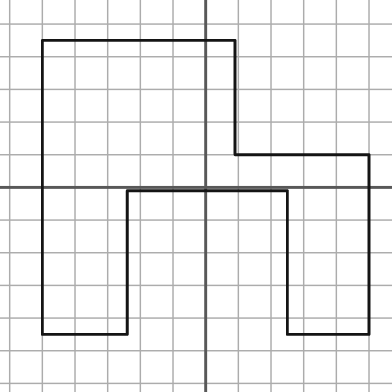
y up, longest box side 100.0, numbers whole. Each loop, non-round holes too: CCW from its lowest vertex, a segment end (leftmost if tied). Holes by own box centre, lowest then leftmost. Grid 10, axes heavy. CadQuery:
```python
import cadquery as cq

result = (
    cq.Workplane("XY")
    .moveTo(-50.0, -45.0)
    .lineTo(-24.0, -45.0)
    .lineTo(-24.0, -1.0)
    .lineTo(25.0, -1.0)
    .lineTo(25.0, -45.0)
    .lineTo(50.0, -45.0)
    .lineTo(50.0, 10.0)
    .lineTo(9.0, 10.0)
    .lineTo(9.0, 45.0)
    .lineTo(-50.0, 45.0)
    .close()
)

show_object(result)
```